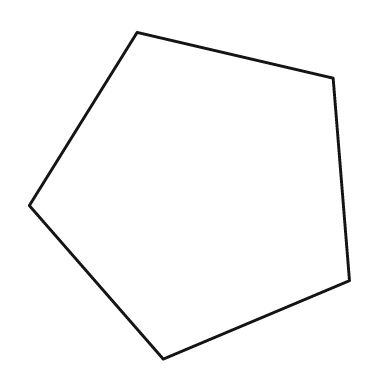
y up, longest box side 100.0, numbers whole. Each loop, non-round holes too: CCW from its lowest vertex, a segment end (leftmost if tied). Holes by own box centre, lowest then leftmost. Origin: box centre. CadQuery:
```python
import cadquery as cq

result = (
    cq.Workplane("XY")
    .moveTo(-8.0, -50.0)
    .lineTo(49.0, -26.0)
    .lineTo(44.0, 36.0)
    .lineTo(-16.0, 50.0)
    .lineTo(-49.0, -3.0)
    .close()
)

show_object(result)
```